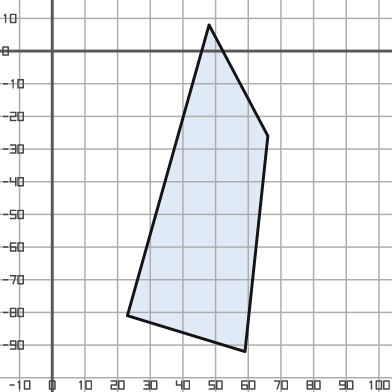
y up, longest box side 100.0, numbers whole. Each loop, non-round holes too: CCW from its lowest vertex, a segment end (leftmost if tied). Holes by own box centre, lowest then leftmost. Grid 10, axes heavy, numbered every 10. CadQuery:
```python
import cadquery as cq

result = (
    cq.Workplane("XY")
    .moveTo(59.0, -92.0)
    .lineTo(66.0, -26.0)
    .lineTo(48.0, 8.0)
    .lineTo(23.0, -81.0)
    .close()
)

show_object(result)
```